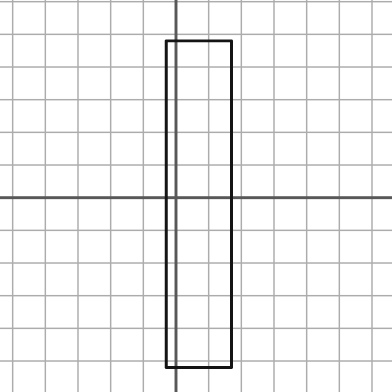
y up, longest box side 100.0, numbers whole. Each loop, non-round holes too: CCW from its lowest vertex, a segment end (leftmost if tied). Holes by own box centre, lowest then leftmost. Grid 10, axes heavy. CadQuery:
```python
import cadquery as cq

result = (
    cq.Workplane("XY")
    .moveTo(-3.0, -52.0)
    .lineTo(17.0, -52.0)
    .lineTo(17.0, 48.0)
    .lineTo(-3.0, 48.0)
    .close()
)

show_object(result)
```